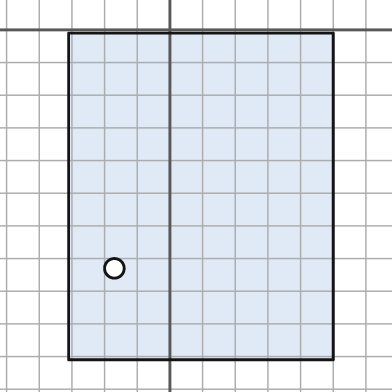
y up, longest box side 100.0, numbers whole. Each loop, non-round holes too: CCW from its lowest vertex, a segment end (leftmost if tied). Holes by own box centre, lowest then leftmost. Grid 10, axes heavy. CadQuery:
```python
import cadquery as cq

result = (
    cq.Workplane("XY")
    .moveTo(-31.0, -101.0)
    .lineTo(50.0, -101.0)
    .lineTo(50.0, -1.0)
    .lineTo(-31.0, -1.0)
    .close()
    .moveTo(-17.0, -73.0)
    .circle(3.0)
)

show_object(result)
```